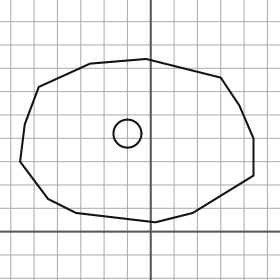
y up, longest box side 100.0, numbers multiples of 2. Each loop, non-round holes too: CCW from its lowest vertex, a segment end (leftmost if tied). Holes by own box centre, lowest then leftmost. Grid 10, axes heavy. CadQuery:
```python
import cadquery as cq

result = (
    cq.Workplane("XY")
    .moveTo(2.0, 4.0)
    .lineTo(18.0, 8.0)
    .lineTo(44.0, 24.0)
    .lineTo(44.0, 40.0)
    .lineTo(38.0, 54.0)
    .lineTo(30.0, 66.0)
    .lineTo(-2.0, 74.0)
    .lineTo(-26.0, 72.0)
    .lineTo(-48.0, 62.0)
    .lineTo(-54.0, 46.0)
    .lineTo(-56.0, 30.0)
    .lineTo(-44.0, 14.0)
    .lineTo(-32.0, 8.0)
    .close()
    .moveTo(-10.0, 42.0)
    .circle(6.0)
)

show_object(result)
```